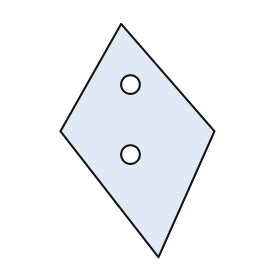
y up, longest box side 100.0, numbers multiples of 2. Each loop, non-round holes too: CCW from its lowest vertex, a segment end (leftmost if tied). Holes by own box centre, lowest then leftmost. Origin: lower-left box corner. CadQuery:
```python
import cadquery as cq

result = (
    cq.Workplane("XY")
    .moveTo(42.0, 0.0)
    .lineTo(66.0, 54.0)
    .lineTo(26.0, 100.0)
    .lineTo(0.0, 54.0)
    .close()
    .moveTo(30.0, 44.0)
    .circle(4.0)
    .moveTo(30.0, 74.0)
    .circle(4.0)
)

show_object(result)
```